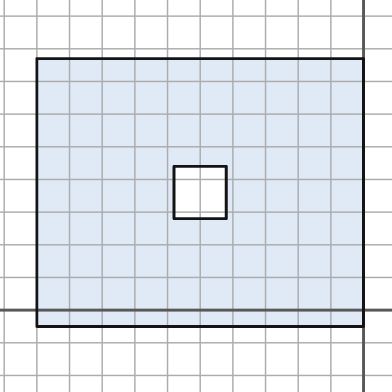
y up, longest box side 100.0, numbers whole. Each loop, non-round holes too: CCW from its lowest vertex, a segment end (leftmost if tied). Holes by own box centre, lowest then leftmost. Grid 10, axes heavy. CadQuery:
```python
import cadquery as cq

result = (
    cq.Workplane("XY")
    .moveTo(-100.0, -5.0)
    .lineTo(0.0, -5.0)
    .lineTo(0.0, 77.0)
    .lineTo(-100.0, 77.0)
    .close()
    .moveTo(-58.0, 28.0)
    .lineTo(-42.0, 28.0)
    .lineTo(-42.0, 44.0)
    .lineTo(-58.0, 44.0)
    .close()
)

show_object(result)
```